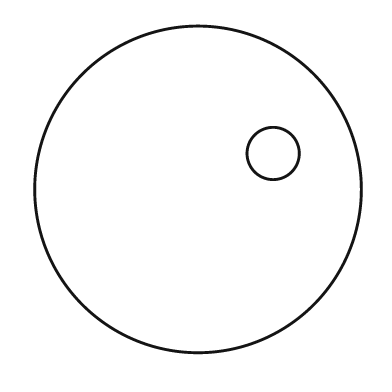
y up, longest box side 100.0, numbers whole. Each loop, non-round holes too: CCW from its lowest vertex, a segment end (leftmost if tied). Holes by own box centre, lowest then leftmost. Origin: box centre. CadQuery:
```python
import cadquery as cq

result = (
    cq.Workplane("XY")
    .moveTo(0.0, 0.0)
    .circle(50.0)
    .moveTo(23.0, 11.0)
    .circle(8.0)
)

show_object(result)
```